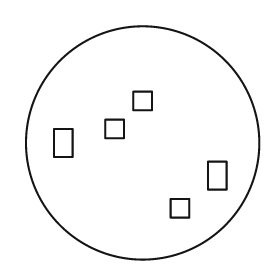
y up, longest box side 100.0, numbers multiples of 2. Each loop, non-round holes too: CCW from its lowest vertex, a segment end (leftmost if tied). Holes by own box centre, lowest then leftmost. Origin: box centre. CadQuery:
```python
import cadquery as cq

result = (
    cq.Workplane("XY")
    .moveTo(0.0, 0.0)
    .circle(50.0)
    .moveTo(12.0, -32.0)
    .lineTo(20.0, -32.0)
    .lineTo(20.0, -24.0)
    .lineTo(12.0, -24.0)
    .close()
    .moveTo(28.0, -20.0)
    .lineTo(36.0, -20.0)
    .lineTo(36.0, -8.0)
    .lineTo(28.0, -8.0)
    .close()
    .moveTo(-38.0, -6.0)
    .lineTo(-30.0, -6.0)
    .lineTo(-30.0, 6.0)
    .lineTo(-38.0, 6.0)
    .close()
    .moveTo(-16.0, 2.0)
    .lineTo(-8.0, 2.0)
    .lineTo(-8.0, 10.0)
    .lineTo(-16.0, 10.0)
    .close()
    .moveTo(-4.0, 14.0)
    .lineTo(4.0, 14.0)
    .lineTo(4.0, 22.0)
    .lineTo(-4.0, 22.0)
    .close()
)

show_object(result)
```